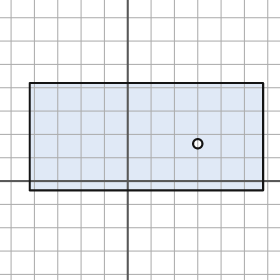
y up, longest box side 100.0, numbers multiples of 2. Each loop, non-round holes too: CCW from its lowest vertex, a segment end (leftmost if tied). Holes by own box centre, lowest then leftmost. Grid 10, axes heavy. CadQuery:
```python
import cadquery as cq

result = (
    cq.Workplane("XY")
    .moveTo(-42.0, -4.0)
    .lineTo(58.0, -4.0)
    .lineTo(58.0, 42.0)
    .lineTo(-42.0, 42.0)
    .close()
    .moveTo(30.0, 16.0)
    .circle(2.0)
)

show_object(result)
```